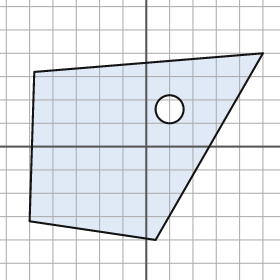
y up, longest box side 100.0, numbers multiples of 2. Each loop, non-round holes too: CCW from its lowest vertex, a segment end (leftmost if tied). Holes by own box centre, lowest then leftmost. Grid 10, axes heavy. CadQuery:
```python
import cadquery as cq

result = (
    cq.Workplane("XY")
    .moveTo(4.0, -40.0)
    .lineTo(50.0, 40.0)
    .lineTo(-48.0, 32.0)
    .lineTo(-50.0, -32.0)
    .close()
    .moveTo(10.0, 16.0)
    .circle(6.0)
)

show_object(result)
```